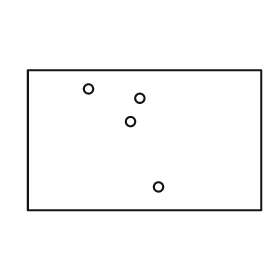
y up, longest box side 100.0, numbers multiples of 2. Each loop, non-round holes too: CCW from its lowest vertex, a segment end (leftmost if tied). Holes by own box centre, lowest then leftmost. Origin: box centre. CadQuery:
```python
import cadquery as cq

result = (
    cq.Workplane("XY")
    .moveTo(-50.0, -30.0)
    .lineTo(50.0, -30.0)
    .lineTo(50.0, 30.0)
    .lineTo(-50.0, 30.0)
    .close()
    .moveTo(6.0, -20.0)
    .circle(2.0)
    .moveTo(-6.0, 8.0)
    .circle(2.0)
    .moveTo(-2.0, 18.0)
    .circle(2.0)
    .moveTo(-24.0, 22.0)
    .circle(2.0)
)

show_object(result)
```